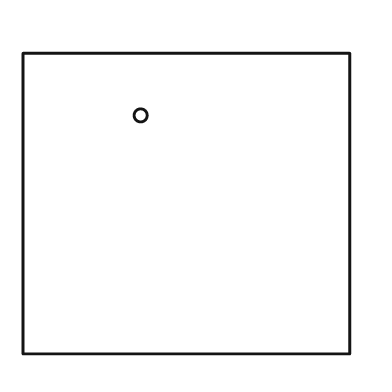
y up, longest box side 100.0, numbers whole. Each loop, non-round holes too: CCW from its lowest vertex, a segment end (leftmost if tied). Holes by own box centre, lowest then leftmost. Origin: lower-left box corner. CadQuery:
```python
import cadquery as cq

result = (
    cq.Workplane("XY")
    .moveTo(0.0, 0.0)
    .lineTo(100.0, 0.0)
    .lineTo(100.0, 92.0)
    .lineTo(0.0, 92.0)
    .close()
    .moveTo(36.0, 73.0)
    .circle(2.0)
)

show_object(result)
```